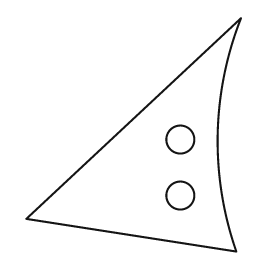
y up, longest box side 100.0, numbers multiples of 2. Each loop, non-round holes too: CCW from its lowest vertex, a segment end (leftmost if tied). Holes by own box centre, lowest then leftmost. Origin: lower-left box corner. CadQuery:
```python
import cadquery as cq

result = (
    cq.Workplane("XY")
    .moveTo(90.0, 0.0)
    .threePointArc((82.0, 50.0), (92.0, 100.0))
    .lineTo(0.0, 14.0)
    .close()
    .moveTo(66.0, 24.0)
    .circle(6.0)
    .moveTo(66.0, 48.0)
    .circle(6.0)
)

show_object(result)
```